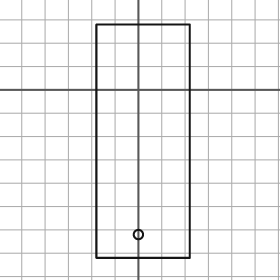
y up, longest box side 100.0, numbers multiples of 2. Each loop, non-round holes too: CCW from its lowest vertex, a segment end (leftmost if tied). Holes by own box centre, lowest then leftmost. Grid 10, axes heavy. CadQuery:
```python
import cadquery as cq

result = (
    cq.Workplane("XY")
    .moveTo(-18.0, -72.0)
    .lineTo(22.0, -72.0)
    .lineTo(22.0, 28.0)
    .lineTo(-18.0, 28.0)
    .close()
    .moveTo(0.0, -62.0)
    .circle(2.0)
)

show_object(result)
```